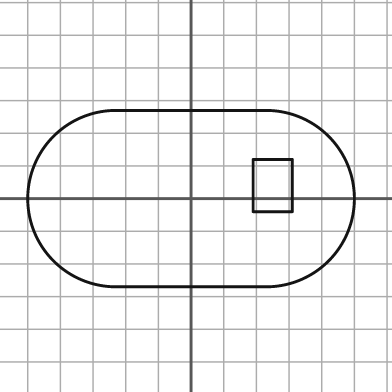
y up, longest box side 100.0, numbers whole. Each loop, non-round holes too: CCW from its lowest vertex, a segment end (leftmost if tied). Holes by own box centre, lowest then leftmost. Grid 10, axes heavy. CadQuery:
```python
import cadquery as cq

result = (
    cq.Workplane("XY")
    .moveTo(-23.0, -27.0)
    .lineTo(23.0, -27.0)
    .threePointArc((50.0, 0.0), (23.0, 27.0))
    .lineTo(-23.0, 27.0)
    .threePointArc((-50.0, 0.0), (-23.0, -27.0))
    .close()
    .moveTo(19.0, -4.0)
    .lineTo(31.0, -4.0)
    .lineTo(31.0, 12.0)
    .lineTo(19.0, 12.0)
    .close()
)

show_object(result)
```